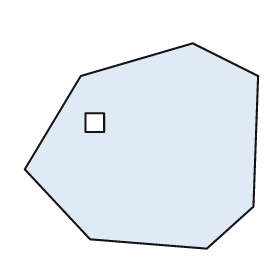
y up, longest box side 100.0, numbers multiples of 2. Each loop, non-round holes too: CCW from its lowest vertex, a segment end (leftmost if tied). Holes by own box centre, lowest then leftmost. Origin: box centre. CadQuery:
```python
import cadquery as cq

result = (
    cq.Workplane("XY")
    .moveTo(28.0, -44.0)
    .lineTo(48.0, -26.0)
    .lineTo(50.0, 30.0)
    .lineTo(22.0, 44.0)
    .lineTo(-26.0, 30.0)
    .lineTo(-50.0, -10.0)
    .lineTo(-22.0, -40.0)
    .close()
    .moveTo(-24.0, 6.0)
    .lineTo(-16.0, 6.0)
    .lineTo(-16.0, 14.0)
    .lineTo(-24.0, 14.0)
    .close()
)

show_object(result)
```